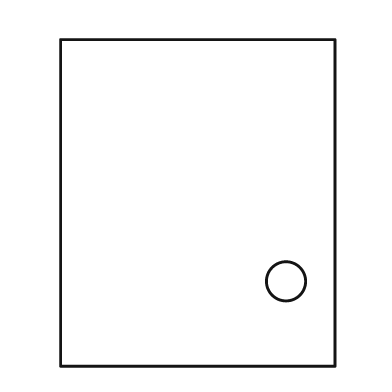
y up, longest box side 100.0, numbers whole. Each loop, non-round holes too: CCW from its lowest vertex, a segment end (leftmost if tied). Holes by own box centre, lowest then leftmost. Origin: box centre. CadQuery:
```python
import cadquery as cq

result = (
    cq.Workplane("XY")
    .moveTo(-42.0, -50.0)
    .lineTo(42.0, -50.0)
    .lineTo(42.0, 50.0)
    .lineTo(-42.0, 50.0)
    .close()
    .moveTo(27.0, -24.0)
    .circle(6.0)
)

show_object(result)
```